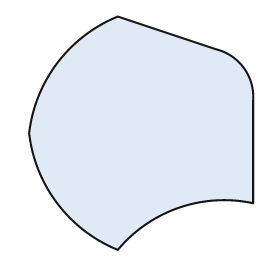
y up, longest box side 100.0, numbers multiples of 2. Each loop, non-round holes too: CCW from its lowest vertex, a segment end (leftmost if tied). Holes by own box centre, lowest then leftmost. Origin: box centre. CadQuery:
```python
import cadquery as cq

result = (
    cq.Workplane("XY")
    .moveTo(-10.0, -50.0)
    .threePointArc((16.0, -32.0), (48.0, -30.0))
    .lineTo(48.0, 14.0)
    .threePointArc((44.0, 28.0), (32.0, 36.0))
    .lineTo(-10.0, 50.0)
    .threePointArc((-36.0, 30.0), (-48.0, 0.0))
    .threePointArc((-36.0, -30.0), (-10.0, -50.0))
    .close()
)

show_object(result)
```